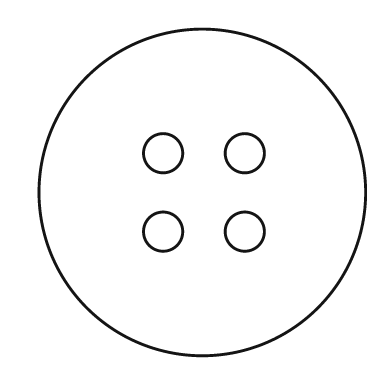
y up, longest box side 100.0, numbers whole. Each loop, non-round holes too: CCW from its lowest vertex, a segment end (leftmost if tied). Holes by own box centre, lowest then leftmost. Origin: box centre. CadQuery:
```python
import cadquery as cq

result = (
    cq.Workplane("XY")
    .moveTo(0.0, 0.0)
    .circle(50.0)
    .moveTo(-12.0, -12.0)
    .circle(6.0)
    .moveTo(13.0, -12.0)
    .circle(6.0)
    .moveTo(-12.0, 12.0)
    .circle(6.0)
    .moveTo(13.0, 12.0)
    .circle(6.0)
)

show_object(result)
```